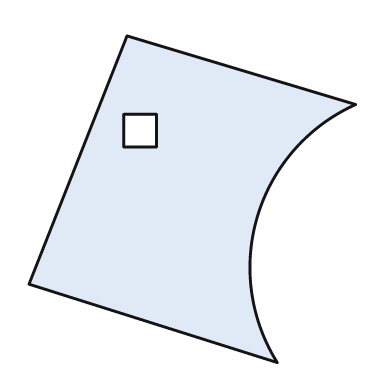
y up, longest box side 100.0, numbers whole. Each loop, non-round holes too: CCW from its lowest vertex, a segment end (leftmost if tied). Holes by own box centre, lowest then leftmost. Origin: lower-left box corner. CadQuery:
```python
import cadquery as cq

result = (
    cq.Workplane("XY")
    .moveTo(76.0, 0.0)
    .threePointArc((70.0, 45.0), (100.0, 79.0))
    .lineTo(30.0, 100.0)
    .lineTo(0.0, 24.0)
    .close()
    .moveTo(29.0, 66.0)
    .lineTo(39.0, 66.0)
    .lineTo(39.0, 76.0)
    .lineTo(29.0, 76.0)
    .close()
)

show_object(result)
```